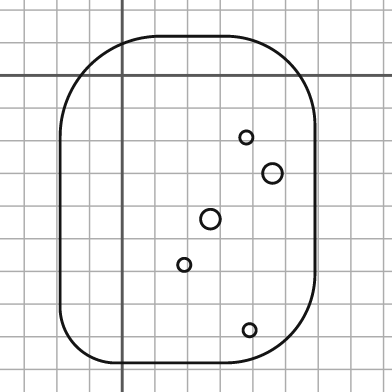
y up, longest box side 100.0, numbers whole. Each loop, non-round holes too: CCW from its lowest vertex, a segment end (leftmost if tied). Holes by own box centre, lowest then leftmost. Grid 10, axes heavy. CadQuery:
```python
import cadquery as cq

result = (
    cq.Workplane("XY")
    .moveTo(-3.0, -88.0)
    .lineTo(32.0, -88.0)
    .threePointArc((51.0, -80.0), (59.0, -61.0))
    .lineTo(59.0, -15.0)
    .threePointArc((51.0, 4.0), (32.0, 12.0))
    .lineTo(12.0, 12.0)
    .threePointArc((-10.0, 3.0), (-19.0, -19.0))
    .lineTo(-19.0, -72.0)
    .threePointArc((-14.0, -83.0), (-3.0, -88.0))
    .close()
    .moveTo(39.0, -78.0)
    .circle(2.0)
    .moveTo(19.0, -58.0)
    .circle(2.0)
    .moveTo(27.0, -44.0)
    .circle(3.0)
    .moveTo(46.0, -30.0)
    .circle(3.0)
    .moveTo(38.0, -19.0)
    .circle(2.0)
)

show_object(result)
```